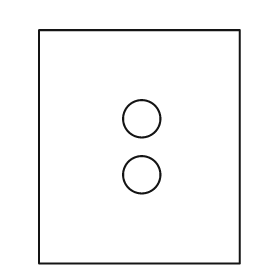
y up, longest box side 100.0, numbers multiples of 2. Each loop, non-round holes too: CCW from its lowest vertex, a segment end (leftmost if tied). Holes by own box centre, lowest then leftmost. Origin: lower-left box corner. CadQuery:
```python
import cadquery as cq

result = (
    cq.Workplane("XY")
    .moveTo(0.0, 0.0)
    .lineTo(86.0, 0.0)
    .lineTo(86.0, 100.0)
    .lineTo(0.0, 100.0)
    .close()
    .moveTo(44.0, 38.0)
    .circle(8.0)
    .moveTo(44.0, 62.0)
    .circle(8.0)
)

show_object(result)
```